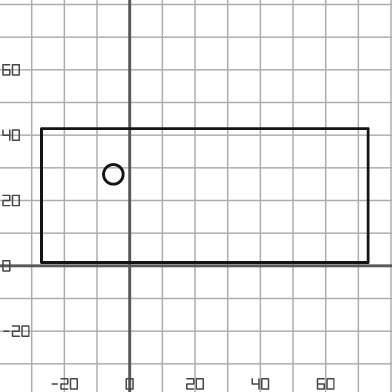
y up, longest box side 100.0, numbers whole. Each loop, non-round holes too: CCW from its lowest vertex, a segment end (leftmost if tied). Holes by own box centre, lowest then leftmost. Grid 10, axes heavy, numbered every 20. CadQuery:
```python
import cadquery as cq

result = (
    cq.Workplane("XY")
    .moveTo(-27.0, 1.0)
    .lineTo(73.0, 1.0)
    .lineTo(73.0, 42.0)
    .lineTo(-27.0, 42.0)
    .close()
    .moveTo(-5.0, 28.0)
    .circle(3.0)
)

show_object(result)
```